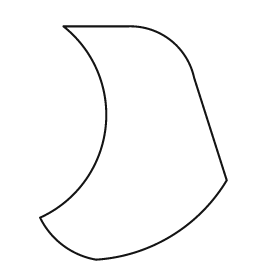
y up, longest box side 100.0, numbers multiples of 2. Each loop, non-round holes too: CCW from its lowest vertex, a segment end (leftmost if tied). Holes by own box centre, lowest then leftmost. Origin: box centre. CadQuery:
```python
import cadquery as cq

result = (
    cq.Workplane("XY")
    .moveTo(-16.0, -50.0)
    .threePointArc((16.0, -40.0), (40.0, -16.0))
    .lineTo(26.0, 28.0)
    .threePointArc((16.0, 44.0), (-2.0, 50.0))
    .lineTo(-30.0, 50.0)
    .threePointArc((-12.0, 6.0), (-40.0, -32.0))
    .threePointArc((-30.0, -44.0), (-16.0, -50.0))
    .close()
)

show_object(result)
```